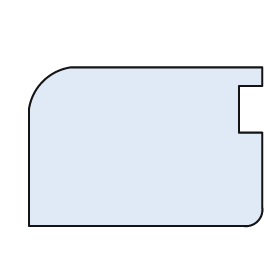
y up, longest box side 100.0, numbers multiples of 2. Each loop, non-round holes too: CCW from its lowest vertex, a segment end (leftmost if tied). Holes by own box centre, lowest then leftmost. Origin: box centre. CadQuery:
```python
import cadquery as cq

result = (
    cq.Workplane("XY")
    .moveTo(-50.0, -34.0)
    .lineTo(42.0, -34.0)
    .threePointArc((48.0, -32.0), (50.0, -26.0))
    .lineTo(50.0, 6.0)
    .lineTo(40.0, 6.0)
    .lineTo(40.0, 26.0)
    .lineTo(50.0, 26.0)
    .lineTo(50.0, 34.0)
    .lineTo(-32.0, 34.0)
    .threePointArc((-44.0, 28.0), (-50.0, 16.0))
    .close()
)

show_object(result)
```